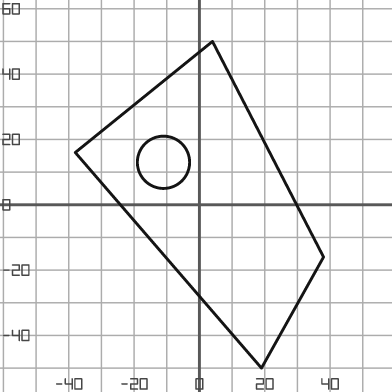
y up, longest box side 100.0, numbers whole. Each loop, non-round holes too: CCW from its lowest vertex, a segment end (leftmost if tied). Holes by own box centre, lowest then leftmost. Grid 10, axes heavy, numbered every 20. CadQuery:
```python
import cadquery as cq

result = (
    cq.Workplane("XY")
    .moveTo(19.0, -50.0)
    .lineTo(38.0, -16.0)
    .lineTo(4.0, 50.0)
    .lineTo(-38.0, 16.0)
    .close()
    .moveTo(-11.0, 13.0)
    .circle(8.0)
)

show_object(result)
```